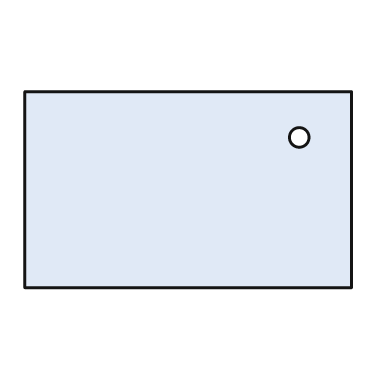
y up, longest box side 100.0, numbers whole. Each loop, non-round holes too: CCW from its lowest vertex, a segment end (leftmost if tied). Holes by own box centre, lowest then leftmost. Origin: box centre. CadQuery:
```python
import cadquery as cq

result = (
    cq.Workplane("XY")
    .moveTo(-50.0, -30.0)
    .lineTo(50.0, -30.0)
    .lineTo(50.0, 30.0)
    .lineTo(-50.0, 30.0)
    .close()
    .moveTo(34.0, 16.0)
    .circle(3.0)
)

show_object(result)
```